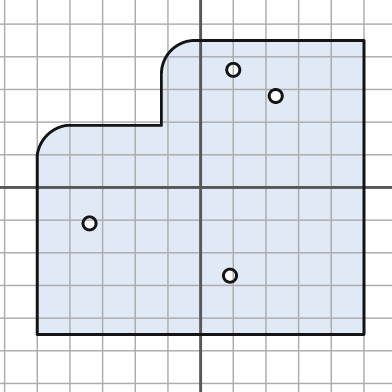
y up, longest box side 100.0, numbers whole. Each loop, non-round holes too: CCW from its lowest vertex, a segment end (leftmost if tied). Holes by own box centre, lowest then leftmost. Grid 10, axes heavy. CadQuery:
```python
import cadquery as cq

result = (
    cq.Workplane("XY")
    .moveTo(-50.0, -45.0)
    .lineTo(50.0, -45.0)
    .lineTo(50.0, 45.0)
    .lineTo(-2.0, 45.0)
    .threePointArc((-9.0, 42.0), (-12.0, 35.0))
    .lineTo(-12.0, 19.0)
    .lineTo(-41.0, 19.0)
    .threePointArc((-47.0, 16.0), (-50.0, 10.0))
    .close()
    .moveTo(9.0, -27.0)
    .circle(2.0)
    .moveTo(-34.0, -11.0)
    .circle(2.0)
    .moveTo(23.0, 28.0)
    .circle(2.0)
    .moveTo(10.0, 36.0)
    .circle(2.0)
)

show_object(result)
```